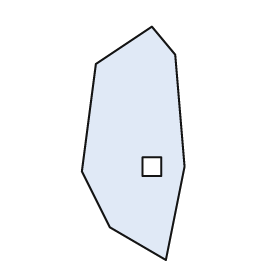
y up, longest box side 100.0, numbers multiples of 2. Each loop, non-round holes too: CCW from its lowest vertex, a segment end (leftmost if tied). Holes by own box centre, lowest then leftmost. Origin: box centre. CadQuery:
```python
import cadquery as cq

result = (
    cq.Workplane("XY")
    .moveTo(14.0, -50.0)
    .lineTo(22.0, -10.0)
    .lineTo(18.0, 38.0)
    .lineTo(8.0, 50.0)
    .lineTo(-16.0, 34.0)
    .lineTo(-22.0, -12.0)
    .lineTo(-10.0, -36.0)
    .close()
    .moveTo(4.0, -14.0)
    .lineTo(12.0, -14.0)
    .lineTo(12.0, -6.0)
    .lineTo(4.0, -6.0)
    .close()
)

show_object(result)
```